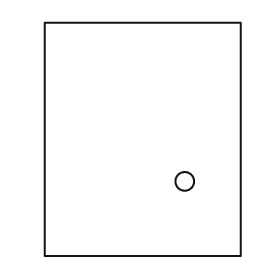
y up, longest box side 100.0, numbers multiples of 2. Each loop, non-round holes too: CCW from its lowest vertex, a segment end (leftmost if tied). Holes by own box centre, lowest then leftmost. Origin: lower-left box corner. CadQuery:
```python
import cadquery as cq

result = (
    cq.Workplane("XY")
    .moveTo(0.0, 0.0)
    .lineTo(84.0, 0.0)
    .lineTo(84.0, 100.0)
    .lineTo(0.0, 100.0)
    .close()
    .moveTo(60.0, 32.0)
    .circle(4.0)
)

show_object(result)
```